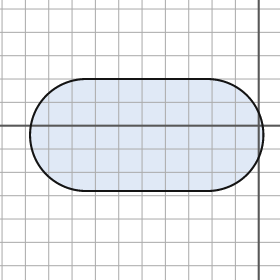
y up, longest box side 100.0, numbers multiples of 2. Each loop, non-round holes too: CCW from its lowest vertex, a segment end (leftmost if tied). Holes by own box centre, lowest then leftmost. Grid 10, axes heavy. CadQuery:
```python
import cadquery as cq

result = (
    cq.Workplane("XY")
    .moveTo(-74.0, -28.0)
    .lineTo(-22.0, -28.0)
    .threePointArc((2.0, -4.0), (-22.0, 20.0))
    .lineTo(-74.0, 20.0)
    .threePointArc((-98.0, -4.0), (-74.0, -28.0))
    .close()
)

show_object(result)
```